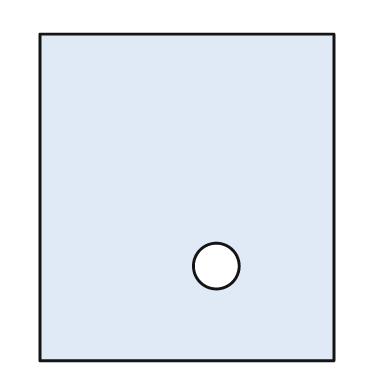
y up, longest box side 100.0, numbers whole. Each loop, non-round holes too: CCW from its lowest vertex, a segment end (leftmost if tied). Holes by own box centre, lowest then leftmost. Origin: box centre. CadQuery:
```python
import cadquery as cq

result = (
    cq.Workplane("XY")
    .moveTo(-45.0, -50.0)
    .lineTo(45.0, -50.0)
    .lineTo(45.0, 50.0)
    .lineTo(-45.0, 50.0)
    .close()
    .moveTo(9.0, -21.0)
    .circle(7.0)
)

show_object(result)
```